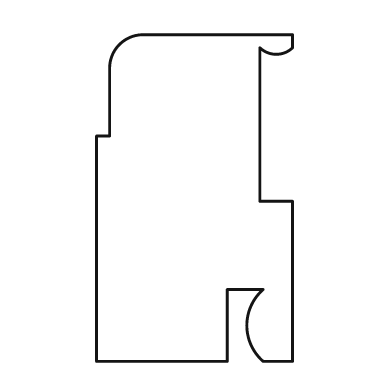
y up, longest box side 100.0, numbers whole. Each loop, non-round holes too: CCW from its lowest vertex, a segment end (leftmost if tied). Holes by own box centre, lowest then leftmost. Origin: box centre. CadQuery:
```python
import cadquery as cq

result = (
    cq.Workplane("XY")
    .moveTo(-30.0, -50.0)
    .lineTo(10.0, -50.0)
    .lineTo(10.0, -28.0)
    .lineTo(21.0, -28.0)
    .threePointArc((16.0, -39.0), (21.0, -50.0))
    .lineTo(30.0, -50.0)
    .lineTo(30.0, -1.0)
    .lineTo(20.0, -1.0)
    .lineTo(20.0, 46.0)
    .threePointArc((25.0, 44.0), (30.0, 46.0))
    .lineTo(30.0, 50.0)
    .lineTo(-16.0, 50.0)
    .threePointArc((-23.0, 47.0), (-26.0, 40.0))
    .lineTo(-26.0, 19.0)
    .lineTo(-30.0, 19.0)
    .close()
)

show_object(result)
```